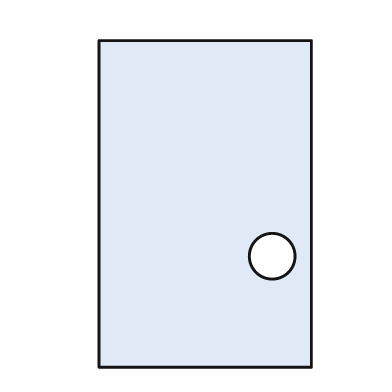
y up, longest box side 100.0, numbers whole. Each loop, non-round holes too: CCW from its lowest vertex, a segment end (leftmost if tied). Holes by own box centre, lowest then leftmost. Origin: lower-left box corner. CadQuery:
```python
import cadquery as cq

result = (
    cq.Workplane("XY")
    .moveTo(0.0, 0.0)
    .lineTo(65.0, 0.0)
    .lineTo(65.0, 100.0)
    .lineTo(0.0, 100.0)
    .close()
    .moveTo(53.0, 34.0)
    .circle(7.0)
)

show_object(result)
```